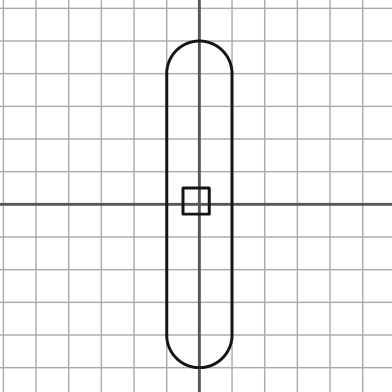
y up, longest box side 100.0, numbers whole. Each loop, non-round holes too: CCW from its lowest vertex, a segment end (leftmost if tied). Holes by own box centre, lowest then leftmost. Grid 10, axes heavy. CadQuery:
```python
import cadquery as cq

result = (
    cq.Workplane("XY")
    .moveTo(-10.0, -40.0)
    .threePointArc((0.0, -50.0), (10.0, -40.0))
    .lineTo(10.0, 40.0)
    .threePointArc((0.0, 50.0), (-10.0, 40.0))
    .close()
    .moveTo(-5.0, -3.0)
    .lineTo(3.0, -3.0)
    .lineTo(3.0, 5.0)
    .lineTo(-5.0, 5.0)
    .close()
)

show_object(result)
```